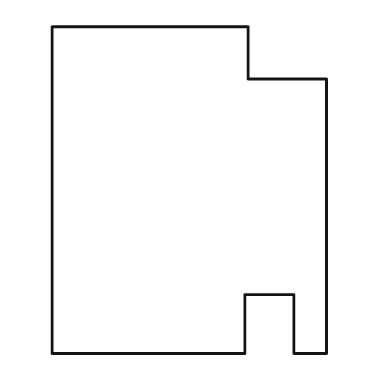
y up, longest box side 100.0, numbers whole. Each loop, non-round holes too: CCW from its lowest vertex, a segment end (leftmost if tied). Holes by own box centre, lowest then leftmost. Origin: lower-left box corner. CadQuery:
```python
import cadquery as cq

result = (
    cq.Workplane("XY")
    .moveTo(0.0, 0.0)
    .lineTo(59.0, 0.0)
    .lineTo(59.0, 18.0)
    .lineTo(74.0, 18.0)
    .lineTo(74.0, 0.0)
    .lineTo(84.0, 0.0)
    .lineTo(84.0, 84.0)
    .lineTo(60.0, 84.0)
    .lineTo(60.0, 100.0)
    .lineTo(0.0, 100.0)
    .close()
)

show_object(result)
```